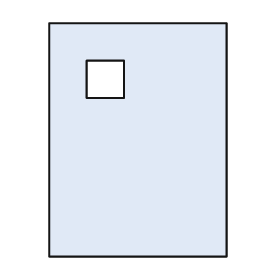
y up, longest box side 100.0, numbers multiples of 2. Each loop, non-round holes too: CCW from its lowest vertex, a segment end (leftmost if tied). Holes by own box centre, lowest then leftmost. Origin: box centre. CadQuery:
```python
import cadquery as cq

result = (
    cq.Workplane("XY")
    .moveTo(-38.0, -50.0)
    .lineTo(38.0, -50.0)
    .lineTo(38.0, 50.0)
    .lineTo(-38.0, 50.0)
    .close()
    .moveTo(-22.0, 18.0)
    .lineTo(-6.0, 18.0)
    .lineTo(-6.0, 34.0)
    .lineTo(-22.0, 34.0)
    .close()
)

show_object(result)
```